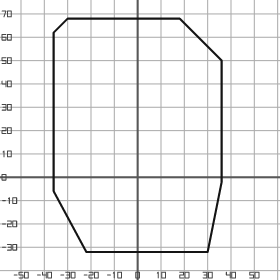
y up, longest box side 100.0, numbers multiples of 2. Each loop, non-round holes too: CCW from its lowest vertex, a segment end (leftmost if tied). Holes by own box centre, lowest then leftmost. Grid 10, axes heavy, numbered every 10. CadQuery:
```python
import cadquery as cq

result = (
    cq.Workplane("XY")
    .moveTo(-22.0, -32.0)
    .lineTo(30.0, -32.0)
    .lineTo(36.0, -2.0)
    .lineTo(36.0, 50.0)
    .lineTo(18.0, 68.0)
    .lineTo(-30.0, 68.0)
    .lineTo(-36.0, 62.0)
    .lineTo(-36.0, -6.0)
    .close()
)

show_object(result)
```